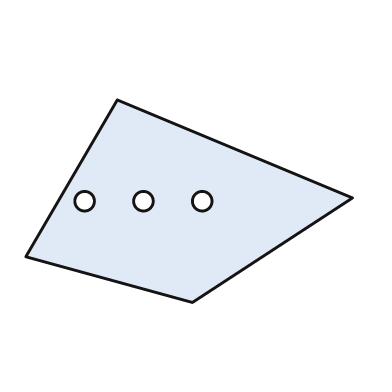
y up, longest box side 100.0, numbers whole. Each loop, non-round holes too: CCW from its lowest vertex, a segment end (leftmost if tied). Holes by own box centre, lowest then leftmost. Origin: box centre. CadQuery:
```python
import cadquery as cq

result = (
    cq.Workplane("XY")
    .moveTo(1.0, -31.0)
    .lineTo(50.0, 1.0)
    .lineTo(-22.0, 31.0)
    .lineTo(-50.0, -17.0)
    .close()
    .moveTo(-32.0, 0.0)
    .circle(3.0)
    .moveTo(-14.0, 0.0)
    .circle(3.0)
    .moveTo(4.0, 0.0)
    .circle(3.0)
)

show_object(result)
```